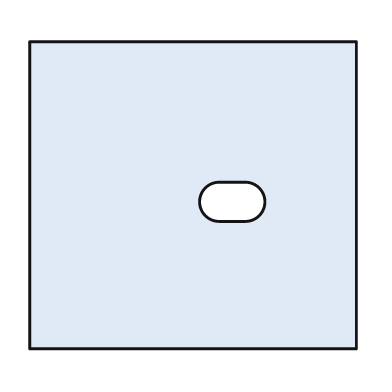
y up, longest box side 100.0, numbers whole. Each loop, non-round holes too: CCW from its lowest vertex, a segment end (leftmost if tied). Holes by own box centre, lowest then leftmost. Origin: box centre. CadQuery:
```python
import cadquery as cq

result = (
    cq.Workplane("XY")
    .moveTo(-50.0, -47.0)
    .lineTo(50.0, -47.0)
    .lineTo(50.0, 47.0)
    .lineTo(-50.0, 47.0)
    .close()
    .moveTo(8.0, -8.0)
    .lineTo(16.0, -8.0)
    .threePointArc((22.0, -2.0), (16.0, 4.0))
    .lineTo(8.0, 4.0)
    .threePointArc((2.0, -2.0), (8.0, -8.0))
    .close()
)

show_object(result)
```